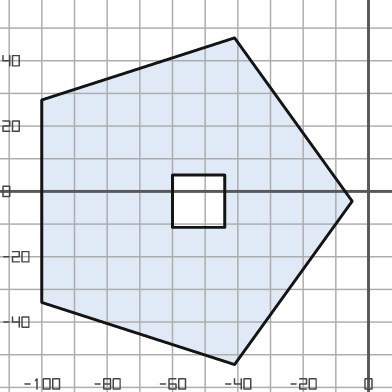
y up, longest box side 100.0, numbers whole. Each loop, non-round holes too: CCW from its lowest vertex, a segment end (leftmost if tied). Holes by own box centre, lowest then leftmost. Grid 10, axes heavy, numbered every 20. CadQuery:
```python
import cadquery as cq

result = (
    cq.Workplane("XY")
    .moveTo(-41.0, -53.0)
    .lineTo(-5.0, -3.0)
    .lineTo(-41.0, 47.0)
    .lineTo(-100.0, 28.0)
    .lineTo(-100.0, -34.0)
    .close()
    .moveTo(-60.0, -11.0)
    .lineTo(-44.0, -11.0)
    .lineTo(-44.0, 5.0)
    .lineTo(-60.0, 5.0)
    .close()
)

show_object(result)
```